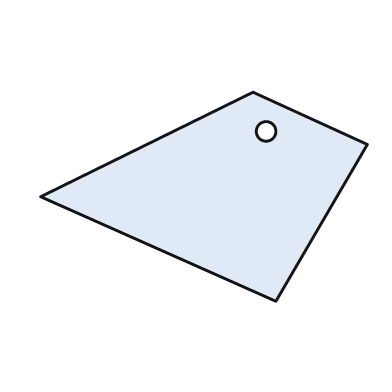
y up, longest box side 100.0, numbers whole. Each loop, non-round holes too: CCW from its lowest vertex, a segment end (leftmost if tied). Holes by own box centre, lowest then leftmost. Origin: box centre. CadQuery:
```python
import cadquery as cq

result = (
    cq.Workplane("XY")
    .moveTo(22.0, -32.0)
    .lineTo(50.0, 16.0)
    .lineTo(15.0, 32.0)
    .lineTo(-50.0, 0.0)
    .close()
    .moveTo(19.0, 20.0)
    .circle(3.0)
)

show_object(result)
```